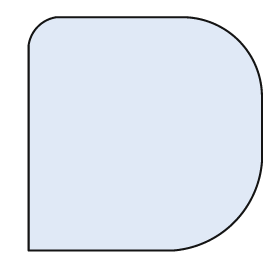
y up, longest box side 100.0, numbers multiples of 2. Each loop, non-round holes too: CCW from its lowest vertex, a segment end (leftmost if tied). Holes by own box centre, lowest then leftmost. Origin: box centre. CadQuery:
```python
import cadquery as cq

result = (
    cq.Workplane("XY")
    .moveTo(-50.0, -50.0)
    .lineTo(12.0, -50.0)
    .threePointArc((38.0, -38.0), (50.0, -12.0))
    .lineTo(50.0, 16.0)
    .threePointArc((40.0, 40.0), (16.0, 50.0))
    .lineTo(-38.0, 50.0)
    .threePointArc((-46.0, 46.0), (-50.0, 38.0))
    .close()
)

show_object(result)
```